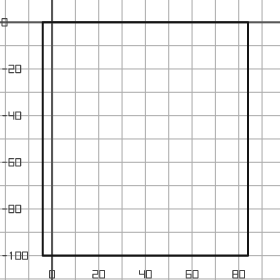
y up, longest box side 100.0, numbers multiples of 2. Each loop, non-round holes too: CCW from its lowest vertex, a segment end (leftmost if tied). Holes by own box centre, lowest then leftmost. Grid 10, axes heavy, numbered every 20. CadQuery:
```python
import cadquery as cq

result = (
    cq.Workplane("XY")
    .moveTo(-4.0, -100.0)
    .lineTo(84.0, -100.0)
    .lineTo(84.0, 0.0)
    .lineTo(-4.0, 0.0)
    .close()
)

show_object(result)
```